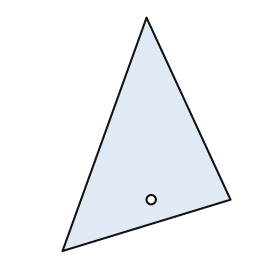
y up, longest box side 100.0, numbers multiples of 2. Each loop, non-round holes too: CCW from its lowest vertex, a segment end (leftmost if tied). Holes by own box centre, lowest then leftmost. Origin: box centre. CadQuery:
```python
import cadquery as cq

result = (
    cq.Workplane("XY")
    .moveTo(-36.0, -50.0)
    .lineTo(36.0, -28.0)
    .lineTo(0.0, 50.0)
    .close()
    .moveTo(2.0, -28.0)
    .circle(2.0)
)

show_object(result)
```